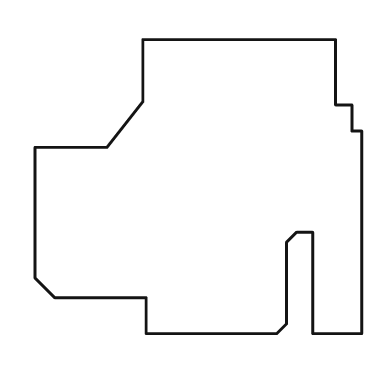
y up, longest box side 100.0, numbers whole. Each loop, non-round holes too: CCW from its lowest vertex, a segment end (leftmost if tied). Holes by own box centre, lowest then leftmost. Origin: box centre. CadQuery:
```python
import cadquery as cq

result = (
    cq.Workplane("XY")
    .moveTo(-16.0, -45.0)
    .lineTo(24.0, -45.0)
    .lineTo(27.0, -42.0)
    .lineTo(27.0, -17.0)
    .lineTo(30.0, -14.0)
    .lineTo(35.0, -14.0)
    .lineTo(35.0, -45.0)
    .lineTo(50.0, -45.0)
    .lineTo(50.0, 17.0)
    .lineTo(47.0, 17.0)
    .lineTo(47.0, 25.0)
    .lineTo(42.0, 25.0)
    .lineTo(42.0, 45.0)
    .lineTo(-17.0, 45.0)
    .lineTo(-17.0, 26.0)
    .lineTo(-28.0, 12.0)
    .lineTo(-50.0, 12.0)
    .lineTo(-50.0, -28.0)
    .lineTo(-44.0, -34.0)
    .lineTo(-16.0, -34.0)
    .close()
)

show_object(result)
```